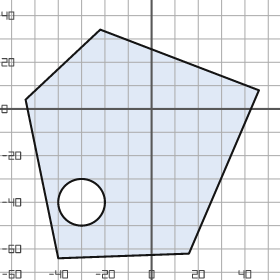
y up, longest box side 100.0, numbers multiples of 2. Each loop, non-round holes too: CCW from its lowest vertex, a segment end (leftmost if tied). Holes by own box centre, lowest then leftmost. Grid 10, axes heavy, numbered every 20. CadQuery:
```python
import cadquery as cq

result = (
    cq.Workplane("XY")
    .moveTo(-40.0, -64.0)
    .lineTo(16.0, -62.0)
    .lineTo(46.0, 8.0)
    .lineTo(-22.0, 34.0)
    .lineTo(-54.0, 4.0)
    .close()
    .moveTo(-30.0, -40.0)
    .circle(10.0)
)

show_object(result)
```